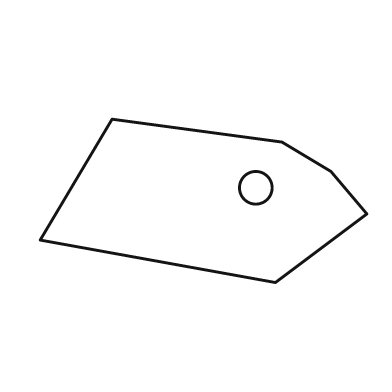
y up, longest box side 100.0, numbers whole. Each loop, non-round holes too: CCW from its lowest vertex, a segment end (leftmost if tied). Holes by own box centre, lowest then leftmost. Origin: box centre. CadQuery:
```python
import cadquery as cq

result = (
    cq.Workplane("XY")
    .moveTo(22.0, -25.0)
    .lineTo(50.0, -4.0)
    .lineTo(39.0, 9.0)
    .lineTo(24.0, 18.0)
    .lineTo(-28.0, 25.0)
    .lineTo(-50.0, -12.0)
    .close()
    .moveTo(16.0, 4.0)
    .circle(5.0)
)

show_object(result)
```